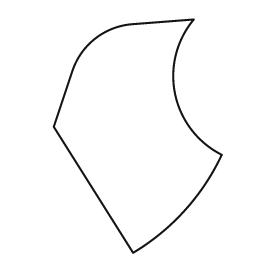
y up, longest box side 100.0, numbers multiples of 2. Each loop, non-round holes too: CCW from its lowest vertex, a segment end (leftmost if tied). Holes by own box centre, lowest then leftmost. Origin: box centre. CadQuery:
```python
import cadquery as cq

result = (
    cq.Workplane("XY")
    .moveTo(-2.0, -50.0)
    .threePointArc((20.0, -32.0), (36.0, -8.0))
    .threePointArc((16.0, 18.0), (24.0, 50.0))
    .lineTo(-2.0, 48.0)
    .threePointArc((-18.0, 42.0), (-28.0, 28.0))
    .lineTo(-36.0, 4.0)
    .close()
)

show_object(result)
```